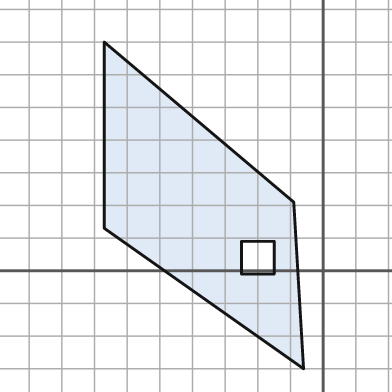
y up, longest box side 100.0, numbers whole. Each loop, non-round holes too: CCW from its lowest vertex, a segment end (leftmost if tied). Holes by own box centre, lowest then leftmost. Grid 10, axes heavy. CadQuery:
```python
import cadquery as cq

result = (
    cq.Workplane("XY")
    .moveTo(-6.0, -30.0)
    .lineTo(-9.0, 21.0)
    .lineTo(-67.0, 70.0)
    .lineTo(-67.0, 13.0)
    .close()
    .moveTo(-25.0, -1.0)
    .lineTo(-15.0, -1.0)
    .lineTo(-15.0, 9.0)
    .lineTo(-25.0, 9.0)
    .close()
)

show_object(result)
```